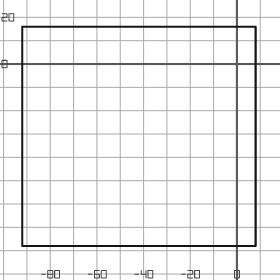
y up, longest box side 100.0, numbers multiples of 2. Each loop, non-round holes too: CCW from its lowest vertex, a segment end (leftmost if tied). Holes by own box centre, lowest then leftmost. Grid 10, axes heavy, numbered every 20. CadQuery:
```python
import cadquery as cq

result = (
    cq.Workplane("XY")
    .moveTo(-92.0, -78.0)
    .lineTo(8.0, -78.0)
    .lineTo(8.0, 16.0)
    .lineTo(-92.0, 16.0)
    .close()
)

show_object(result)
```